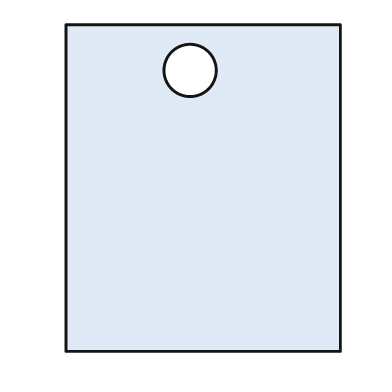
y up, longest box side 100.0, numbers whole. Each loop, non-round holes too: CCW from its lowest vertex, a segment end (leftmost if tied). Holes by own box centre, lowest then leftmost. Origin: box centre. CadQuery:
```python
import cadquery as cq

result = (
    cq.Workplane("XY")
    .moveTo(-42.0, -50.0)
    .lineTo(42.0, -50.0)
    .lineTo(42.0, 50.0)
    .lineTo(-42.0, 50.0)
    .close()
    .moveTo(-4.0, 36.0)
    .circle(8.0)
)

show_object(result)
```